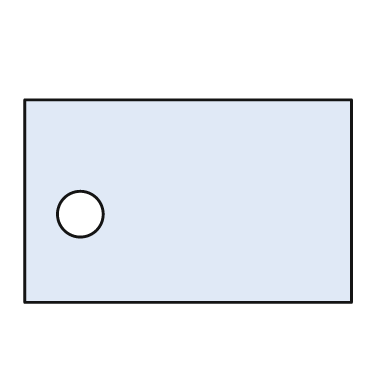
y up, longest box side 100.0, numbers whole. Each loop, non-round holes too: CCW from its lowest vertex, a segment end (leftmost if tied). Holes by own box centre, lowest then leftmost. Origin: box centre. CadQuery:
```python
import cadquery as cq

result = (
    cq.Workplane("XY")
    .moveTo(-50.0, -31.0)
    .lineTo(50.0, -31.0)
    .lineTo(50.0, 31.0)
    .lineTo(-50.0, 31.0)
    .close()
    .moveTo(-33.0, -4.0)
    .circle(7.0)
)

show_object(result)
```